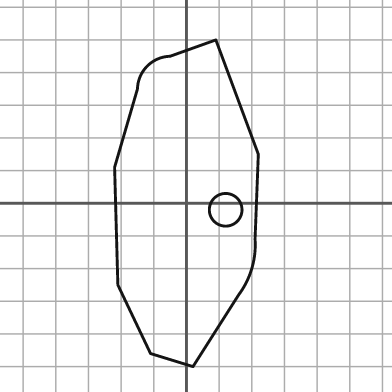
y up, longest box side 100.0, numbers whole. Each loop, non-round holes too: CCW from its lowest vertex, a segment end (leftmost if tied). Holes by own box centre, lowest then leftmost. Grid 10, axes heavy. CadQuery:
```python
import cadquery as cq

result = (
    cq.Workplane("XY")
    .moveTo(2.0, -50.0)
    .lineTo(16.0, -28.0)
    .threePointArc((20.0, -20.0), (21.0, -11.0))
    .lineTo(22.0, 15.0)
    .lineTo(9.0, 50.0)
    .lineTo(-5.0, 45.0)
    .threePointArc((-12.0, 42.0), (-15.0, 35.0))
    .lineTo(-22.0, 11.0)
    .lineTo(-21.0, -25.0)
    .lineTo(-11.0, -46.0)
    .close()
    .moveTo(12.0, -2.0)
    .circle(5.0)
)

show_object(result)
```